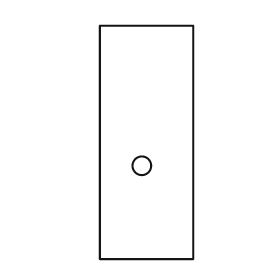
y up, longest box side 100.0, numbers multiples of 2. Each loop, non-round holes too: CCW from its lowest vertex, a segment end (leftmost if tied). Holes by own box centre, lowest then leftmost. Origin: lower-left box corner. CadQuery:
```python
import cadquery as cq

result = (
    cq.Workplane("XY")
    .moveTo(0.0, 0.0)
    .lineTo(40.0, 0.0)
    .lineTo(40.0, 100.0)
    .lineTo(0.0, 100.0)
    .close()
    .moveTo(18.0, 40.0)
    .circle(4.0)
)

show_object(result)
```